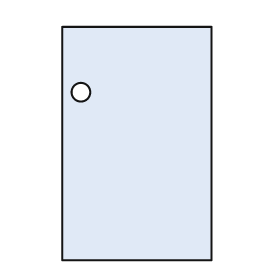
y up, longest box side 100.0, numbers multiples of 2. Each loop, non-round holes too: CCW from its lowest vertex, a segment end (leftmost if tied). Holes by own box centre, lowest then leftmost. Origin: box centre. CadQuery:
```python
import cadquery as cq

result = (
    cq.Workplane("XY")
    .moveTo(-32.0, -50.0)
    .lineTo(32.0, -50.0)
    .lineTo(32.0, 50.0)
    .lineTo(-32.0, 50.0)
    .close()
    .moveTo(-24.0, 22.0)
    .circle(4.0)
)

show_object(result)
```